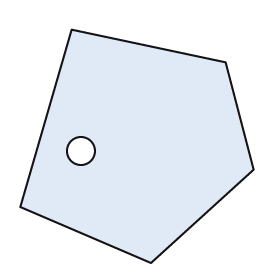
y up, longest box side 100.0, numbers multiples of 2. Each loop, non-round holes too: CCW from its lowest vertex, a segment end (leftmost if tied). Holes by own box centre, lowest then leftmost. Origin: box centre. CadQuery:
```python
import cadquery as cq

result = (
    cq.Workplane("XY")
    .moveTo(6.0, -50.0)
    .lineTo(50.0, -10.0)
    .lineTo(38.0, 36.0)
    .lineTo(-28.0, 50.0)
    .lineTo(-50.0, -26.0)
    .close()
    .moveTo(-24.0, -2.0)
    .circle(6.0)
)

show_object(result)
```